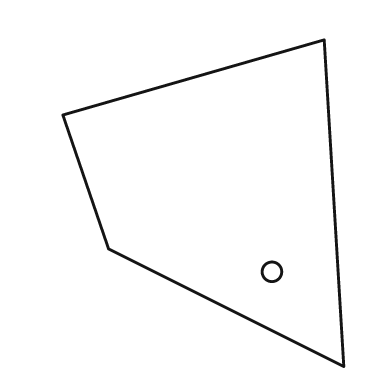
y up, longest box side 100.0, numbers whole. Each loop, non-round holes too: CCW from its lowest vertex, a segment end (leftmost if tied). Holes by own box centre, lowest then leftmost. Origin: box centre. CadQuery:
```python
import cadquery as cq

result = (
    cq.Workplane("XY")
    .moveTo(43.0, -50.0)
    .lineTo(37.0, 50.0)
    .lineTo(-43.0, 27.0)
    .lineTo(-29.0, -14.0)
    .close()
    .moveTo(21.0, -21.0)
    .circle(3.0)
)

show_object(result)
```